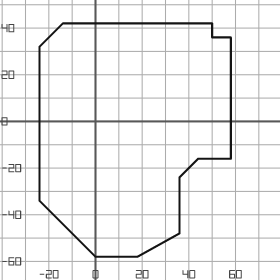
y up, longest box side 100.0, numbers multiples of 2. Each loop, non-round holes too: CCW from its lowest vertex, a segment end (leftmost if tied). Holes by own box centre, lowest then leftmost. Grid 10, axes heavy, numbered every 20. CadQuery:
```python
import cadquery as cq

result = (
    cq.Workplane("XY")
    .moveTo(0.0, -58.0)
    .lineTo(18.0, -58.0)
    .lineTo(36.0, -48.0)
    .lineTo(36.0, -24.0)
    .lineTo(44.0, -16.0)
    .lineTo(58.0, -16.0)
    .lineTo(58.0, 36.0)
    .lineTo(50.0, 36.0)
    .lineTo(50.0, 42.0)
    .lineTo(-14.0, 42.0)
    .lineTo(-24.0, 32.0)
    .lineTo(-24.0, -34.0)
    .close()
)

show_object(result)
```